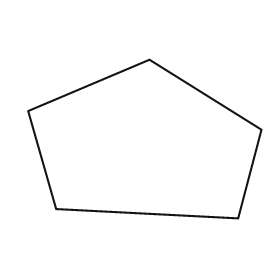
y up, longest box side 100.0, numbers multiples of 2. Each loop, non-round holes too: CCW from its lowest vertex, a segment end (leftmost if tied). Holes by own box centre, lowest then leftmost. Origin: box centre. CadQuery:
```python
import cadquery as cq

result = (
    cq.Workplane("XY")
    .moveTo(40.0, -34.0)
    .lineTo(50.0, 4.0)
    .lineTo(2.0, 34.0)
    .lineTo(-50.0, 12.0)
    .lineTo(-38.0, -30.0)
    .close()
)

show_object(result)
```